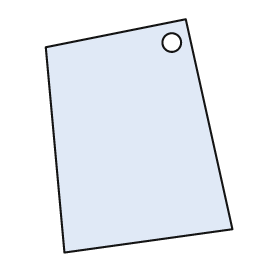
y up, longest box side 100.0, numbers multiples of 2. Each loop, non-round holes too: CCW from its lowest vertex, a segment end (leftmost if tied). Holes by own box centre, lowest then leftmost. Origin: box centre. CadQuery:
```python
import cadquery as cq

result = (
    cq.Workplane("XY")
    .moveTo(-32.0, -50.0)
    .lineTo(40.0, -40.0)
    .lineTo(20.0, 50.0)
    .lineTo(-40.0, 38.0)
    .close()
    .moveTo(14.0, 40.0)
    .circle(4.0)
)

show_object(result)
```